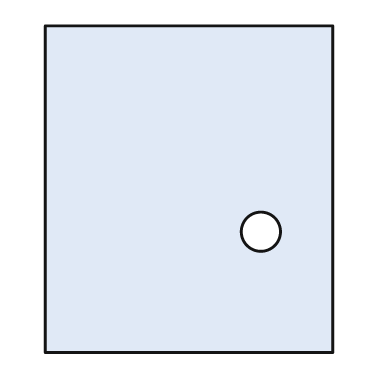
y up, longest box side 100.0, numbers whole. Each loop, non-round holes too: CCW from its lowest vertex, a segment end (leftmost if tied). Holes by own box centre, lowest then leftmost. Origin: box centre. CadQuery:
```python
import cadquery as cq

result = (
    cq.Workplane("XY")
    .moveTo(-44.0, -50.0)
    .lineTo(44.0, -50.0)
    .lineTo(44.0, 50.0)
    .lineTo(-44.0, 50.0)
    .close()
    .moveTo(22.0, -13.0)
    .circle(6.0)
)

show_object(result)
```